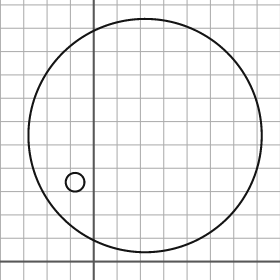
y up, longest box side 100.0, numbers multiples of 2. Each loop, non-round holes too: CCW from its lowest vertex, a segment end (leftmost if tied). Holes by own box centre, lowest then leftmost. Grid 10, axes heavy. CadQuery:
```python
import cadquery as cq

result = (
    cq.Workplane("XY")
    .moveTo(22.0, 54.0)
    .circle(50.0)
    .moveTo(-8.0, 34.0)
    .circle(4.0)
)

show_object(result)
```